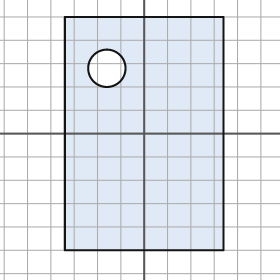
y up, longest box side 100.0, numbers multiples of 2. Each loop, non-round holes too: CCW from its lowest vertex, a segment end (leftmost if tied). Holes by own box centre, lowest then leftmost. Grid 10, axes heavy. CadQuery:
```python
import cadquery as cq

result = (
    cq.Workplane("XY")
    .moveTo(-34.0, -50.0)
    .lineTo(34.0, -50.0)
    .lineTo(34.0, 50.0)
    .lineTo(-34.0, 50.0)
    .close()
    .moveTo(-16.0, 28.0)
    .circle(8.0)
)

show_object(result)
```